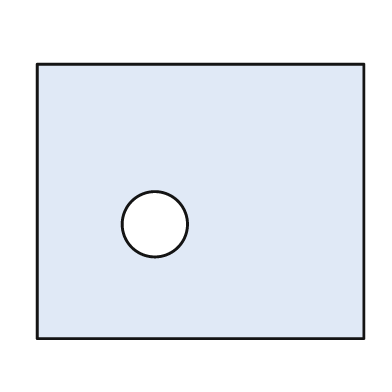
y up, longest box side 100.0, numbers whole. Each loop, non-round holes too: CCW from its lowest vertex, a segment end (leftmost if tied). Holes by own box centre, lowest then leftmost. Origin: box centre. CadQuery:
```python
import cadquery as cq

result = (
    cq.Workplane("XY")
    .moveTo(-50.0, -42.0)
    .lineTo(50.0, -42.0)
    .lineTo(50.0, 42.0)
    .lineTo(-50.0, 42.0)
    .close()
    .moveTo(-14.0, -7.0)
    .circle(10.0)
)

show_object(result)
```